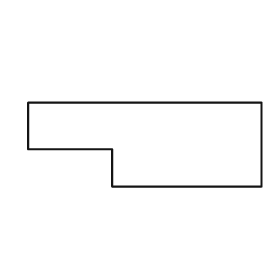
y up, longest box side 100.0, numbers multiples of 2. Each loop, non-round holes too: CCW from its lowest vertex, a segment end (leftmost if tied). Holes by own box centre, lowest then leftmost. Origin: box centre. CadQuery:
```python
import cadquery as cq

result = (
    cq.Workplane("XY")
    .moveTo(-14.0, -18.0)
    .lineTo(50.0, -18.0)
    .lineTo(50.0, 18.0)
    .lineTo(-50.0, 18.0)
    .lineTo(-50.0, -2.0)
    .lineTo(-14.0, -2.0)
    .close()
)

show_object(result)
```